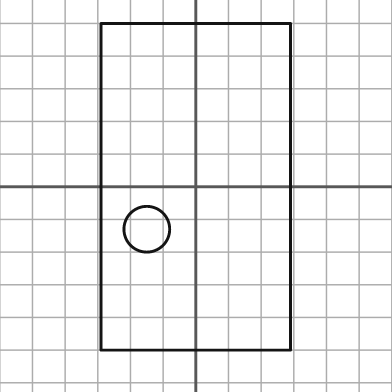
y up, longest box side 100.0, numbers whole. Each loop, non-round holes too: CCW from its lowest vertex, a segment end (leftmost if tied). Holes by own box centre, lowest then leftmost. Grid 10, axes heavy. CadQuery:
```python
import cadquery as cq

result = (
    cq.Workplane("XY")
    .moveTo(-29.0, -50.0)
    .lineTo(29.0, -50.0)
    .lineTo(29.0, 50.0)
    .lineTo(-29.0, 50.0)
    .close()
    .moveTo(-15.0, -13.0)
    .circle(7.0)
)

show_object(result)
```